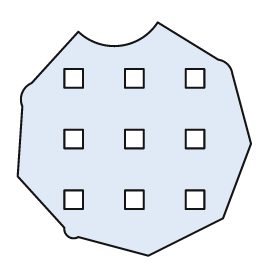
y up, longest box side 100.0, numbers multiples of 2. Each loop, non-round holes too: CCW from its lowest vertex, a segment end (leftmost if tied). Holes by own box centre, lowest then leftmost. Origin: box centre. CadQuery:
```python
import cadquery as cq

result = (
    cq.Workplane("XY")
    .moveTo(6.0, -50.0)
    .lineTo(38.0, -34.0)
    .lineTo(50.0, -2.0)
    .lineTo(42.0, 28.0)
    .threePointArc((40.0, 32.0), (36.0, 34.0))
    .lineTo(10.0, 50.0)
    .threePointArc((-6.0, 40.0), (-24.0, 46.0))
    .lineTo(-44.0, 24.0)
    .threePointArc((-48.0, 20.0), (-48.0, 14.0))
    .lineTo(-50.0, -16.0)
    .lineTo(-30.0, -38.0)
    .threePointArc((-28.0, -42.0), (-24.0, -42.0))
    .close()
    .moveTo(-30.0, -30.0)
    .lineTo(-22.0, -30.0)
    .lineTo(-22.0, -22.0)
    .lineTo(-30.0, -22.0)
    .close()
    .moveTo(-4.0, -30.0)
    .lineTo(4.0, -30.0)
    .lineTo(4.0, -22.0)
    .lineTo(-4.0, -22.0)
    .close()
    .moveTo(22.0, -30.0)
    .lineTo(30.0, -30.0)
    .lineTo(30.0, -22.0)
    .lineTo(22.0, -22.0)
    .close()
    .moveTo(-30.0, -4.0)
    .lineTo(-22.0, -4.0)
    .lineTo(-22.0, 4.0)
    .lineTo(-30.0, 4.0)
    .close()
    .moveTo(-4.0, -4.0)
    .lineTo(4.0, -4.0)
    .lineTo(4.0, 4.0)
    .lineTo(-4.0, 4.0)
    .close()
    .moveTo(22.0, -4.0)
    .lineTo(30.0, -4.0)
    .lineTo(30.0, 4.0)
    .lineTo(22.0, 4.0)
    .close()
    .moveTo(-30.0, 22.0)
    .lineTo(-22.0, 22.0)
    .lineTo(-22.0, 30.0)
    .lineTo(-30.0, 30.0)
    .close()
    .moveTo(-4.0, 22.0)
    .lineTo(4.0, 22.0)
    .lineTo(4.0, 30.0)
    .lineTo(-4.0, 30.0)
    .close()
    .moveTo(22.0, 22.0)
    .lineTo(30.0, 22.0)
    .lineTo(30.0, 30.0)
    .lineTo(22.0, 30.0)
    .close()
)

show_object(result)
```